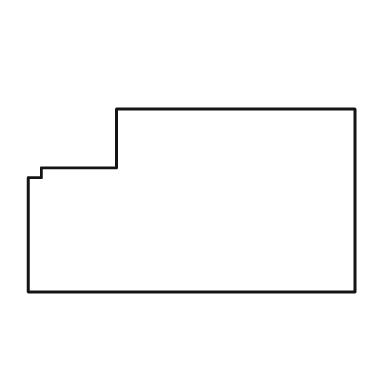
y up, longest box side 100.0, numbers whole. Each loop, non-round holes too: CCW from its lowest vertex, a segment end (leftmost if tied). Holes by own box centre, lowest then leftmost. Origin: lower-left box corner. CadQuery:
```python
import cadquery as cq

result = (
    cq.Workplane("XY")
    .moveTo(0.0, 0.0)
    .lineTo(100.0, 0.0)
    .lineTo(100.0, 56.0)
    .lineTo(27.0, 56.0)
    .lineTo(27.0, 38.0)
    .lineTo(4.0, 38.0)
    .lineTo(4.0, 35.0)
    .lineTo(0.0, 35.0)
    .close()
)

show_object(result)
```